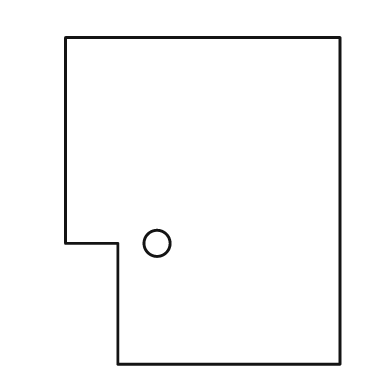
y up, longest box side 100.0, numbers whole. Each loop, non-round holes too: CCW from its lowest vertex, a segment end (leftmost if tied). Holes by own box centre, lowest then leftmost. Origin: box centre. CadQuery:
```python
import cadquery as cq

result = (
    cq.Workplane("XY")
    .moveTo(-26.0, -50.0)
    .lineTo(42.0, -50.0)
    .lineTo(42.0, 50.0)
    .lineTo(-42.0, 50.0)
    .lineTo(-42.0, -13.0)
    .lineTo(-26.0, -13.0)
    .close()
    .moveTo(-14.0, -13.0)
    .circle(4.0)
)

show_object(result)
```